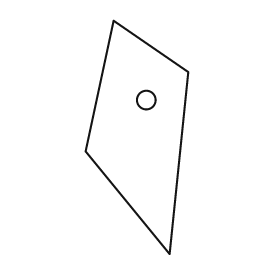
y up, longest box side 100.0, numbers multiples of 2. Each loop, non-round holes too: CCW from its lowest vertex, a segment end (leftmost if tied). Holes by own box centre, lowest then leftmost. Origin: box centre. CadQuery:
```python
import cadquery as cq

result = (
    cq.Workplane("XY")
    .moveTo(14.0, -50.0)
    .lineTo(22.0, 28.0)
    .lineTo(-10.0, 50.0)
    .lineTo(-22.0, -6.0)
    .close()
    .moveTo(4.0, 16.0)
    .circle(4.0)
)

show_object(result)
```